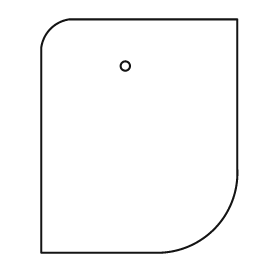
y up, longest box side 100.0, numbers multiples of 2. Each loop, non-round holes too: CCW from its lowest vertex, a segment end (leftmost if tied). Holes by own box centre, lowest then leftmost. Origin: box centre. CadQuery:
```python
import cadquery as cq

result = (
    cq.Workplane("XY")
    .moveTo(-42.0, -50.0)
    .lineTo(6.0, -50.0)
    .threePointArc((32.0, -40.0), (42.0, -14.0))
    .lineTo(42.0, 50.0)
    .lineTo(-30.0, 50.0)
    .threePointArc((-38.0, 46.0), (-42.0, 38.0))
    .close()
    .moveTo(-6.0, 30.0)
    .circle(2.0)
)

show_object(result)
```